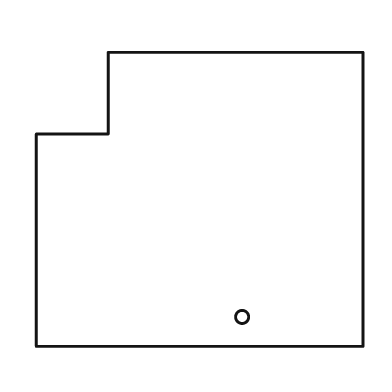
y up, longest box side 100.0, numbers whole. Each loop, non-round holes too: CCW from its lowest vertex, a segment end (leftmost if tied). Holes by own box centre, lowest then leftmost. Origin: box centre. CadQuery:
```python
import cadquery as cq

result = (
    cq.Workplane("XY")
    .moveTo(-50.0, -45.0)
    .lineTo(50.0, -45.0)
    .lineTo(50.0, 45.0)
    .lineTo(-28.0, 45.0)
    .lineTo(-28.0, 20.0)
    .lineTo(-50.0, 20.0)
    .close()
    .moveTo(13.0, -36.0)
    .circle(2.0)
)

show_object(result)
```